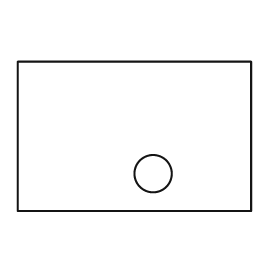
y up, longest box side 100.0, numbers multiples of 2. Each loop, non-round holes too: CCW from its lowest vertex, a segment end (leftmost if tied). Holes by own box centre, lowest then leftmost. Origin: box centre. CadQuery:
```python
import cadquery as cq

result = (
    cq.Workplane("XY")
    .moveTo(-50.0, -32.0)
    .lineTo(50.0, -32.0)
    .lineTo(50.0, 32.0)
    .lineTo(-50.0, 32.0)
    .close()
    .moveTo(8.0, -16.0)
    .circle(8.0)
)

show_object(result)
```